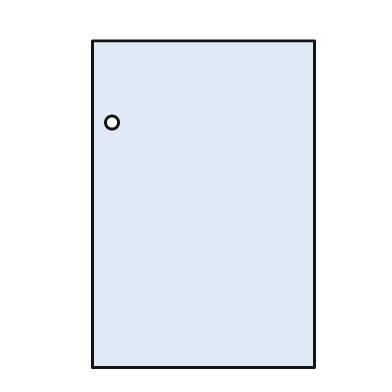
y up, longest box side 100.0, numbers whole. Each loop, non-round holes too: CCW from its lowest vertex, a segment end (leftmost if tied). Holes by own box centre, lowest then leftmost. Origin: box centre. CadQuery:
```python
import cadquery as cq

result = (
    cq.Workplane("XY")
    .moveTo(-34.0, -50.0)
    .lineTo(34.0, -50.0)
    .lineTo(34.0, 50.0)
    .lineTo(-34.0, 50.0)
    .close()
    .moveTo(-28.0, 25.0)
    .circle(2.0)
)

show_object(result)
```